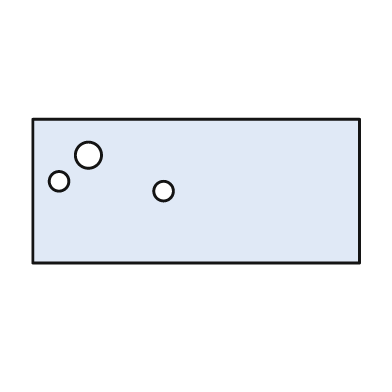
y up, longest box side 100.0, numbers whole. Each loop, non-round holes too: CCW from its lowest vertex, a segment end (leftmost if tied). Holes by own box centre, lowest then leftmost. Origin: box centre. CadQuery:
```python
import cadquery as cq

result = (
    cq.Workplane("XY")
    .moveTo(-50.0, -22.0)
    .lineTo(50.0, -22.0)
    .lineTo(50.0, 22.0)
    .lineTo(-50.0, 22.0)
    .close()
    .moveTo(-10.0, 0.0)
    .circle(3.0)
    .moveTo(-42.0, 3.0)
    .circle(3.0)
    .moveTo(-33.0, 11.0)
    .circle(4.0)
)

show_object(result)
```